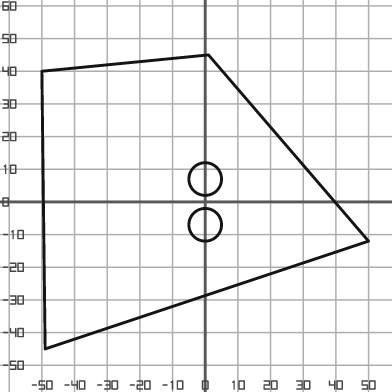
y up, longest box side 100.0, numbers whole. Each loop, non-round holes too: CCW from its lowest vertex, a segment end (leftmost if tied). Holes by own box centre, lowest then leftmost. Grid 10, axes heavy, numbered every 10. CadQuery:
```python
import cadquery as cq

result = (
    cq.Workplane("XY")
    .moveTo(-49.0, -45.0)
    .lineTo(50.0, -12.0)
    .lineTo(1.0, 45.0)
    .lineTo(-50.0, 40.0)
    .close()
    .moveTo(0.0, -7.0)
    .circle(5.0)
    .moveTo(0.0, 7.0)
    .circle(5.0)
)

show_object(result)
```